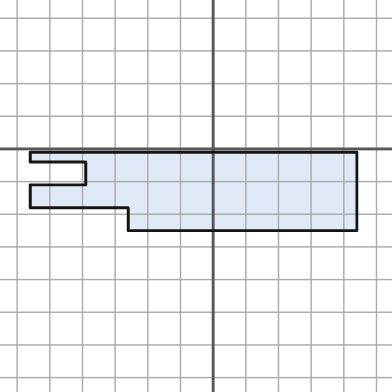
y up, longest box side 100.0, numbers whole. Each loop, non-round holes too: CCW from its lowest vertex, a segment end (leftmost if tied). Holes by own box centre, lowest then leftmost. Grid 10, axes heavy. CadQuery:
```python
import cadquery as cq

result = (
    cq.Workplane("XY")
    .moveTo(-26.0, -25.0)
    .lineTo(44.0, -25.0)
    .lineTo(44.0, -1.0)
    .lineTo(-56.0, -1.0)
    .lineTo(-56.0, -4.0)
    .lineTo(-39.0, -4.0)
    .lineTo(-39.0, -11.0)
    .lineTo(-56.0, -11.0)
    .lineTo(-56.0, -18.0)
    .lineTo(-26.0, -18.0)
    .close()
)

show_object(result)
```